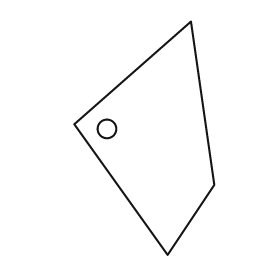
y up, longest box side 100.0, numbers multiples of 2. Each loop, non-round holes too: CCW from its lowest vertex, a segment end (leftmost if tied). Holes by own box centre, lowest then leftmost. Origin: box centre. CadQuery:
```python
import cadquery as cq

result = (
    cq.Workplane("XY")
    .moveTo(10.0, -50.0)
    .lineTo(30.0, -20.0)
    .lineTo(20.0, 50.0)
    .lineTo(-30.0, 6.0)
    .close()
    .moveTo(-16.0, 4.0)
    .circle(4.0)
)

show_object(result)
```